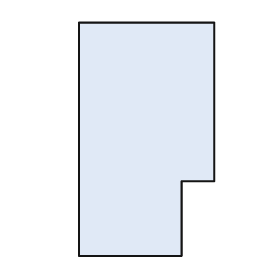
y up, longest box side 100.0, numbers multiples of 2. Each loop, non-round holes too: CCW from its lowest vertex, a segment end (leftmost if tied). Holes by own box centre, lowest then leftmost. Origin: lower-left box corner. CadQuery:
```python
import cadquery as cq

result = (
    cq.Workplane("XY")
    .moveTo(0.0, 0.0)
    .lineTo(44.0, 0.0)
    .lineTo(44.0, 32.0)
    .lineTo(58.0, 32.0)
    .lineTo(58.0, 100.0)
    .lineTo(0.0, 100.0)
    .close()
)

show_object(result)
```